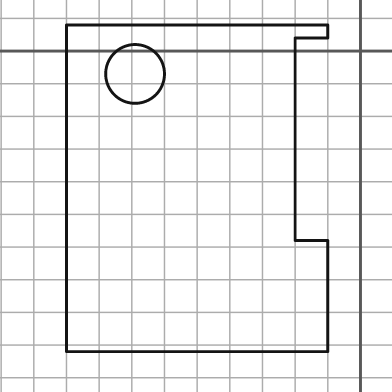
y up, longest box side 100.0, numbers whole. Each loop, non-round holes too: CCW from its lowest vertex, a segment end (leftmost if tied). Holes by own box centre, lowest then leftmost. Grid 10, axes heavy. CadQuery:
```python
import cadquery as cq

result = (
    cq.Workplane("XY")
    .moveTo(-90.0, -92.0)
    .lineTo(-10.0, -92.0)
    .lineTo(-10.0, -58.0)
    .lineTo(-20.0, -58.0)
    .lineTo(-20.0, 4.0)
    .lineTo(-10.0, 4.0)
    .lineTo(-10.0, 8.0)
    .lineTo(-90.0, 8.0)
    .close()
    .moveTo(-69.0, -7.0)
    .circle(9.0)
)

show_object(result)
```